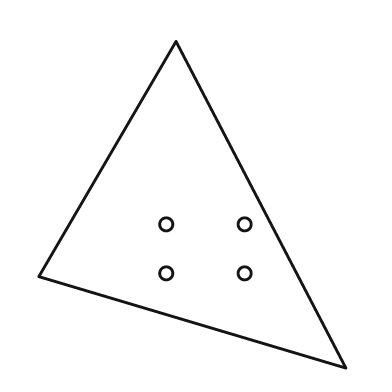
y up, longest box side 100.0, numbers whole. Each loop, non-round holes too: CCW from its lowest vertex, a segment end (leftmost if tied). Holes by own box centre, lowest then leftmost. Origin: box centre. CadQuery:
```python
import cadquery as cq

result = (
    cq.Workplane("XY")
    .moveTo(47.0, -50.0)
    .lineTo(-5.0, 50.0)
    .lineTo(-47.0, -22.0)
    .close()
    .moveTo(-8.0, -21.0)
    .circle(2.0)
    .moveTo(16.0, -21.0)
    .circle(2.0)
    .moveTo(-8.0, -6.0)
    .circle(2.0)
    .moveTo(16.0, -6.0)
    .circle(2.0)
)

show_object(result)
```